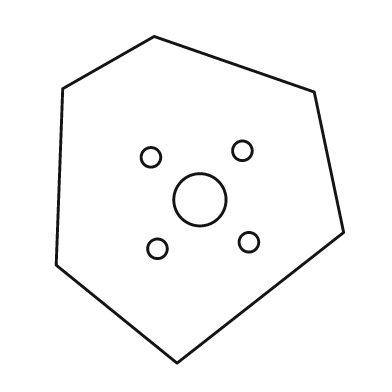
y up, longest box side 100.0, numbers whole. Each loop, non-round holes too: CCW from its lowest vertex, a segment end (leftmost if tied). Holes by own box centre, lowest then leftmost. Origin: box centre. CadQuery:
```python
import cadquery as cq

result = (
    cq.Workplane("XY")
    .moveTo(-7.0, -50.0)
    .lineTo(44.0, -10.0)
    .lineTo(35.0, 33.0)
    .lineTo(-14.0, 50.0)
    .lineTo(-42.0, 34.0)
    .lineTo(-44.0, -20.0)
    .close()
    .moveTo(-13.0, -15.0)
    .circle(3.0)
    .moveTo(15.0, -13.0)
    .circle(3.0)
    .moveTo(0.0, 0.0)
    .circle(8.0)
    .moveTo(-15.0, 13.0)
    .circle(3.0)
    .moveTo(13.0, 15.0)
    .circle(3.0)
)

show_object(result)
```